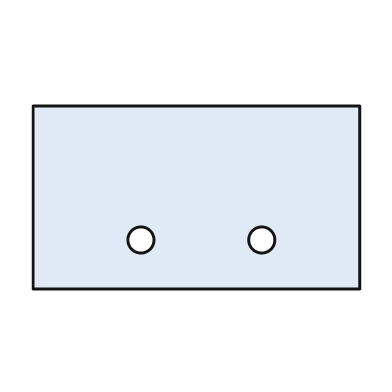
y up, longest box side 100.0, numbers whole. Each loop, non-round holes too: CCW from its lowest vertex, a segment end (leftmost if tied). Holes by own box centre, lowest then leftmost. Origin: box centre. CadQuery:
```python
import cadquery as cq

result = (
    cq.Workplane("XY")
    .moveTo(-50.0, -28.0)
    .lineTo(50.0, -28.0)
    .lineTo(50.0, 28.0)
    .lineTo(-50.0, 28.0)
    .close()
    .moveTo(-17.0, -13.0)
    .circle(4.0)
    .moveTo(20.0, -13.0)
    .circle(4.0)
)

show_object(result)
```